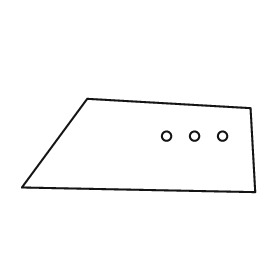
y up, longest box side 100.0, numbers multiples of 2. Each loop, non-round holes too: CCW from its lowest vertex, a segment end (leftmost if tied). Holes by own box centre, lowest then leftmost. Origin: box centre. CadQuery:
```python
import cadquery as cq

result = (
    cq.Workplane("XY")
    .moveTo(50.0, -20.0)
    .lineTo(48.0, 16.0)
    .lineTo(-22.0, 20.0)
    .lineTo(-50.0, -18.0)
    .close()
    .moveTo(12.0, 4.0)
    .circle(2.0)
    .moveTo(24.0, 4.0)
    .circle(2.0)
    .moveTo(36.0, 4.0)
    .circle(2.0)
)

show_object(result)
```